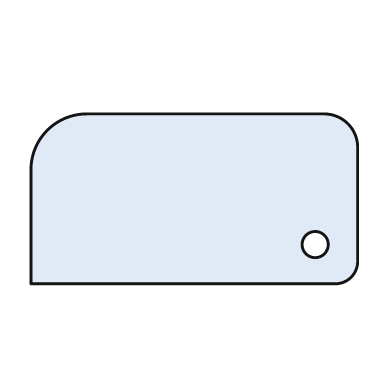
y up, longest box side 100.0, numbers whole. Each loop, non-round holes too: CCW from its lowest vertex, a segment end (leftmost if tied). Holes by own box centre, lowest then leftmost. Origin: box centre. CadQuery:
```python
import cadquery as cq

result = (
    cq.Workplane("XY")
    .moveTo(-50.0, -26.0)
    .lineTo(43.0, -26.0)
    .threePointArc((48.0, -24.0), (50.0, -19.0))
    .lineTo(50.0, 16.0)
    .threePointArc((47.0, 23.0), (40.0, 26.0))
    .lineTo(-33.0, 26.0)
    .threePointArc((-45.0, 21.0), (-50.0, 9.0))
    .close()
    .moveTo(37.0, -14.0)
    .circle(4.0)
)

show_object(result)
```